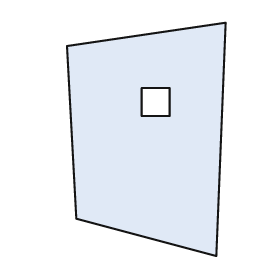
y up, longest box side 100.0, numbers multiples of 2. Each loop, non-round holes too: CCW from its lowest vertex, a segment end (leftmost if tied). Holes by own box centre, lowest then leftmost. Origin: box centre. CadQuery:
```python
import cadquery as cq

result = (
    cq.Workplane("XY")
    .moveTo(30.0, -50.0)
    .lineTo(34.0, 50.0)
    .lineTo(-34.0, 40.0)
    .lineTo(-30.0, -34.0)
    .close()
    .moveTo(-2.0, 10.0)
    .lineTo(10.0, 10.0)
    .lineTo(10.0, 22.0)
    .lineTo(-2.0, 22.0)
    .close()
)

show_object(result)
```